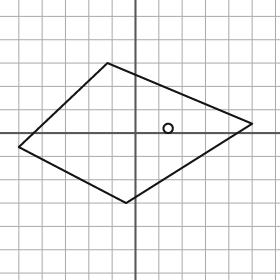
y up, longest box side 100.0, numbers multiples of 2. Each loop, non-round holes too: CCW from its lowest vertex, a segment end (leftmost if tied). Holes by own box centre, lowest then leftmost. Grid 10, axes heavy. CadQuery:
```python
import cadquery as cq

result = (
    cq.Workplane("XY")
    .moveTo(-4.0, -30.0)
    .lineTo(50.0, 4.0)
    .lineTo(-12.0, 30.0)
    .lineTo(-50.0, -6.0)
    .close()
    .moveTo(14.0, 2.0)
    .circle(2.0)
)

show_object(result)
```